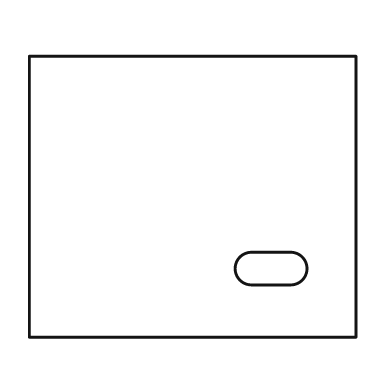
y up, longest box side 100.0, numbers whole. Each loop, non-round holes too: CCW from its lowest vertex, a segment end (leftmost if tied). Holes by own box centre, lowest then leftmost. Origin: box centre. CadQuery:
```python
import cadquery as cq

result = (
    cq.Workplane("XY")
    .moveTo(-50.0, -43.0)
    .lineTo(50.0, -43.0)
    .lineTo(50.0, 43.0)
    .lineTo(-50.0, 43.0)
    .close()
    .moveTo(18.0, -27.0)
    .lineTo(30.0, -27.0)
    .threePointArc((35.0, -22.0), (30.0, -17.0))
    .lineTo(18.0, -17.0)
    .threePointArc((13.0, -22.0), (18.0, -27.0))
    .close()
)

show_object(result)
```